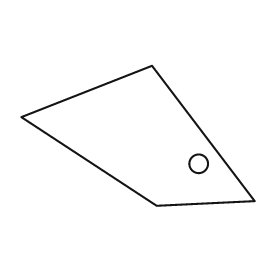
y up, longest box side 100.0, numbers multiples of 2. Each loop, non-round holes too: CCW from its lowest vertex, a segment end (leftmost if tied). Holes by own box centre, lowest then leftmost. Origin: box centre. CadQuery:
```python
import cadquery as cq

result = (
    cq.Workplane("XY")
    .moveTo(8.0, -30.0)
    .lineTo(50.0, -28.0)
    .lineTo(6.0, 30.0)
    .lineTo(-50.0, 8.0)
    .close()
    .moveTo(26.0, -12.0)
    .circle(4.0)
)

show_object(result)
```